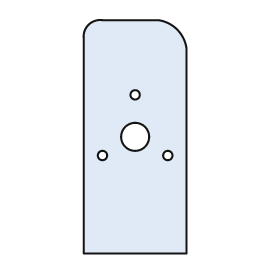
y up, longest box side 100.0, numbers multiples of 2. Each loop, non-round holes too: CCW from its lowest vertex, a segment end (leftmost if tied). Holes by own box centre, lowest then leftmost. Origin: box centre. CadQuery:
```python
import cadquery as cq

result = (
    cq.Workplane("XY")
    .moveTo(-22.0, -50.0)
    .lineTo(22.0, -50.0)
    .lineTo(22.0, 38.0)
    .threePointArc((18.0, 46.0), (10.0, 50.0))
    .lineTo(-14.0, 50.0)
    .threePointArc((-20.0, 48.0), (-22.0, 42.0))
    .close()
    .moveTo(-14.0, -8.0)
    .circle(2.0)
    .moveTo(14.0, -8.0)
    .circle(2.0)
    .moveTo(0.0, 0.0)
    .circle(6.0)
    .moveTo(0.0, 18.0)
    .circle(2.0)
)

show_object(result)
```